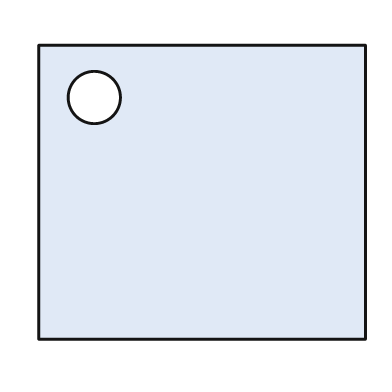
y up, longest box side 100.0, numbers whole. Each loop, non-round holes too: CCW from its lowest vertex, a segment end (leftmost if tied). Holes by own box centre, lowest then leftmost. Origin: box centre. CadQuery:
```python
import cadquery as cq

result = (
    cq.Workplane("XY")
    .moveTo(-50.0, -45.0)
    .lineTo(50.0, -45.0)
    .lineTo(50.0, 45.0)
    .lineTo(-50.0, 45.0)
    .close()
    .moveTo(-33.0, 29.0)
    .circle(8.0)
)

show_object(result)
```